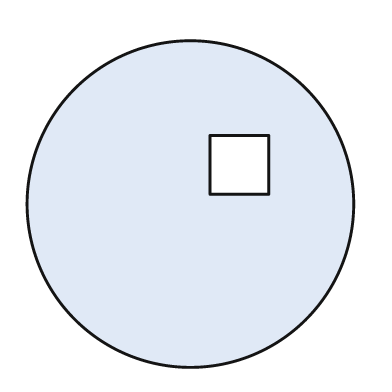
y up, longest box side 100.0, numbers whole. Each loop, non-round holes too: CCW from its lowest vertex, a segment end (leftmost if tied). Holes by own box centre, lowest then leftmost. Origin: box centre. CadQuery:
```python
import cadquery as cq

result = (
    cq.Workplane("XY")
    .moveTo(0.0, 0.0)
    .circle(50.0)
    .moveTo(6.0, 3.0)
    .lineTo(24.0, 3.0)
    .lineTo(24.0, 21.0)
    .lineTo(6.0, 21.0)
    .close()
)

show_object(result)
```